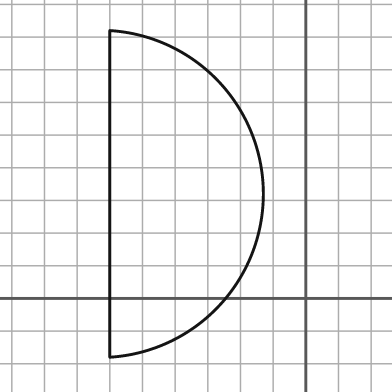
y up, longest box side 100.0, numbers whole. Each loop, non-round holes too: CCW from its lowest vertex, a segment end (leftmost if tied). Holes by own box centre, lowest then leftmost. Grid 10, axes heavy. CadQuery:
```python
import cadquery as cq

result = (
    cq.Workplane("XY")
    .moveTo(-60.0, -18.0)
    .threePointArc((-13.0, 32.0), (-60.0, 82.0))
    .close()
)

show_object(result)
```